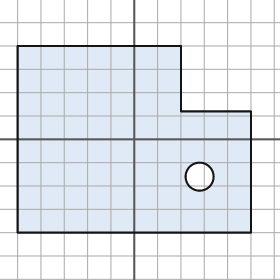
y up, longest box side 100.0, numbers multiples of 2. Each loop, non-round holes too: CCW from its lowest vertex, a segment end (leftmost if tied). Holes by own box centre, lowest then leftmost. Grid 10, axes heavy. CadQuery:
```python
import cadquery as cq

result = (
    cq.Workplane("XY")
    .moveTo(-50.0, -40.0)
    .lineTo(50.0, -40.0)
    .lineTo(50.0, 12.0)
    .lineTo(20.0, 12.0)
    .lineTo(20.0, 40.0)
    .lineTo(-50.0, 40.0)
    .close()
    .moveTo(28.0, -16.0)
    .circle(6.0)
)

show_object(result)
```